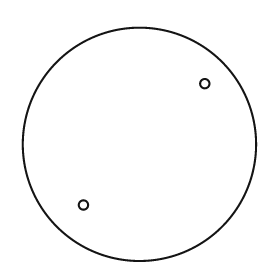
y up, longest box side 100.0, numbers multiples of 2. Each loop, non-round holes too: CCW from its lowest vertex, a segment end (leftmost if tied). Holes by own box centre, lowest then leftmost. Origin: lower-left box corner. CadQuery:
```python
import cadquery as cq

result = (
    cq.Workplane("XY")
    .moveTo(50.0, 50.0)
    .circle(50.0)
    .moveTo(26.0, 24.0)
    .circle(2.0)
    .moveTo(78.0, 76.0)
    .circle(2.0)
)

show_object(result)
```